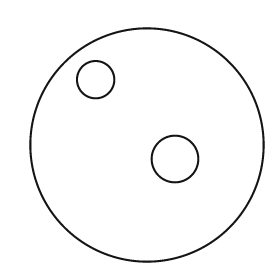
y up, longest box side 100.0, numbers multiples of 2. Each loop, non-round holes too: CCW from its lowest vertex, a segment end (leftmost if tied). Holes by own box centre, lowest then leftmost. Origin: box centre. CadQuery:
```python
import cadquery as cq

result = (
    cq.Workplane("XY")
    .moveTo(0.0, 0.0)
    .circle(50.0)
    .moveTo(12.0, -6.0)
    .circle(10.0)
    .moveTo(-22.0, 28.0)
    .circle(8.0)
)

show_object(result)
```